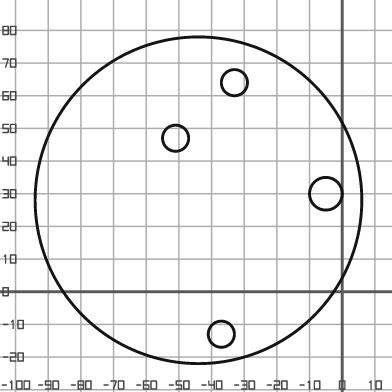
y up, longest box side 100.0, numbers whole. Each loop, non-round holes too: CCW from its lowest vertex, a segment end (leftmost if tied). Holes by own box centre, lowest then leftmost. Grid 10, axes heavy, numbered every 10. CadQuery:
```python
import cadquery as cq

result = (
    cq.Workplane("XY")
    .moveTo(-44.0, 28.0)
    .circle(50.0)
    .moveTo(-37.0, -13.0)
    .circle(4.0)
    .moveTo(-5.0, 30.0)
    .circle(5.0)
    .moveTo(-51.0, 47.0)
    .circle(4.0)
    .moveTo(-33.0, 64.0)
    .circle(4.0)
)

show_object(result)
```